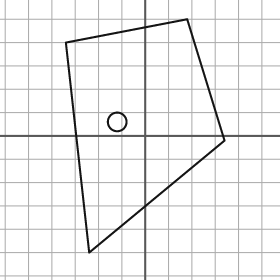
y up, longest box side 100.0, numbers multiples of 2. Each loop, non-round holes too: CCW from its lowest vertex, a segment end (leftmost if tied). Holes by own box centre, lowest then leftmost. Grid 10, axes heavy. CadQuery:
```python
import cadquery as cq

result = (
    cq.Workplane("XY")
    .moveTo(-24.0, -50.0)
    .lineTo(34.0, -2.0)
    .lineTo(18.0, 50.0)
    .lineTo(-34.0, 40.0)
    .close()
    .moveTo(-12.0, 6.0)
    .circle(4.0)
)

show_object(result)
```